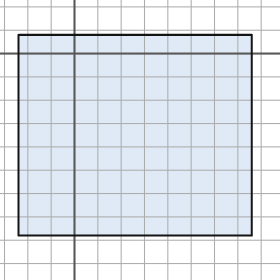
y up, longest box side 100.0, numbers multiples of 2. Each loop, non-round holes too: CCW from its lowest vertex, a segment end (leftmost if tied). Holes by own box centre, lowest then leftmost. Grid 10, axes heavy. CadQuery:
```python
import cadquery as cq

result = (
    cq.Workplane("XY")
    .moveTo(-24.0, -78.0)
    .lineTo(76.0, -78.0)
    .lineTo(76.0, 8.0)
    .lineTo(-24.0, 8.0)
    .close()
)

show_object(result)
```